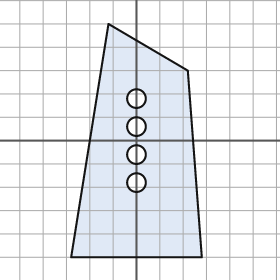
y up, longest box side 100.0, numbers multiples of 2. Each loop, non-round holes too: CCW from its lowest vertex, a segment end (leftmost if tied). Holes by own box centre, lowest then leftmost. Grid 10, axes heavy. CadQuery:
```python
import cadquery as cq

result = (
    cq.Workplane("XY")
    .moveTo(-28.0, -50.0)
    .lineTo(28.0, -50.0)
    .lineTo(22.0, 30.0)
    .lineTo(-12.0, 50.0)
    .close()
    .moveTo(0.0, -18.0)
    .circle(4.0)
    .moveTo(0.0, -6.0)
    .circle(4.0)
    .moveTo(0.0, 6.0)
    .circle(4.0)
    .moveTo(0.0, 18.0)
    .circle(4.0)
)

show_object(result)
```